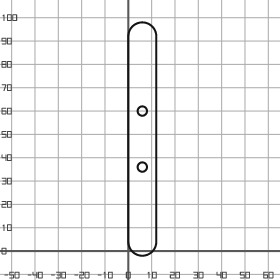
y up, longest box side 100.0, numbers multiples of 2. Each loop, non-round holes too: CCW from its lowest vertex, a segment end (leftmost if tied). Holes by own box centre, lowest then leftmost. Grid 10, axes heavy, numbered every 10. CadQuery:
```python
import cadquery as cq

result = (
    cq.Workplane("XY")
    .moveTo(0.0, 4.0)
    .threePointArc((6.0, -2.0), (12.0, 4.0))
    .lineTo(12.0, 92.0)
    .threePointArc((6.0, 98.0), (0.0, 92.0))
    .close()
    .moveTo(6.0, 36.0)
    .circle(2.0)
    .moveTo(6.0, 60.0)
    .circle(2.0)
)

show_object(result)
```